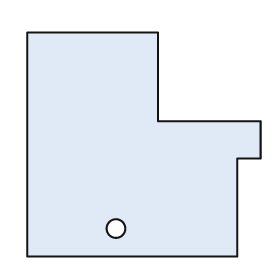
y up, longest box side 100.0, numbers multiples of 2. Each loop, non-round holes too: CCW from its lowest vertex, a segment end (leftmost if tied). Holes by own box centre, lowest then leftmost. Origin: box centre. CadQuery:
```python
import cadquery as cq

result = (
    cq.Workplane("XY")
    .moveTo(-50.0, -48.0)
    .lineTo(40.0, -48.0)
    .lineTo(40.0, -6.0)
    .lineTo(50.0, -6.0)
    .lineTo(50.0, 10.0)
    .lineTo(6.0, 10.0)
    .lineTo(6.0, 48.0)
    .lineTo(-50.0, 48.0)
    .close()
    .moveTo(-12.0, -36.0)
    .circle(4.0)
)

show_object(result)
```